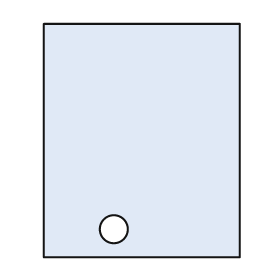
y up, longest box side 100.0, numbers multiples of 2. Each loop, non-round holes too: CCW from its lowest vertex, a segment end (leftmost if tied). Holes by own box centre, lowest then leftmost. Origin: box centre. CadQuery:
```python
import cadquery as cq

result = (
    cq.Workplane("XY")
    .moveTo(-42.0, -50.0)
    .lineTo(42.0, -50.0)
    .lineTo(42.0, 50.0)
    .lineTo(-42.0, 50.0)
    .close()
    .moveTo(-12.0, -38.0)
    .circle(6.0)
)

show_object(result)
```